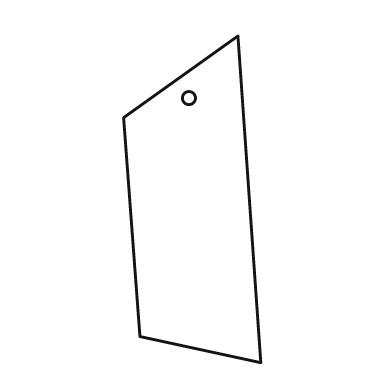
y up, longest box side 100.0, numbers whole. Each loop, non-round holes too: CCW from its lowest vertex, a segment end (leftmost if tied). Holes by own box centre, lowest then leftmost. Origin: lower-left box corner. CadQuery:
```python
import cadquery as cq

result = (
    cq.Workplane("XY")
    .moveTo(42.0, 0.0)
    .lineTo(35.0, 100.0)
    .lineTo(0.0, 75.0)
    .lineTo(5.0, 8.0)
    .close()
    .moveTo(20.0, 81.0)
    .circle(2.0)
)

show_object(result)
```